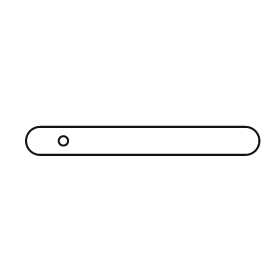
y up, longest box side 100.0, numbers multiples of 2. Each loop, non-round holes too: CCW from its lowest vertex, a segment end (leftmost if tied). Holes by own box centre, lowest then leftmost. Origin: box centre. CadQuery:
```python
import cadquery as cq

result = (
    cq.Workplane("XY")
    .moveTo(-44.0, -6.0)
    .lineTo(44.0, -6.0)
    .threePointArc((50.0, 0.0), (44.0, 6.0))
    .lineTo(-44.0, 6.0)
    .threePointArc((-50.0, 0.0), (-44.0, -6.0))
    .close()
    .moveTo(-34.0, 0.0)
    .circle(2.0)
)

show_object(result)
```